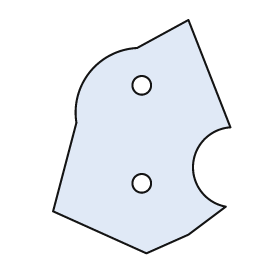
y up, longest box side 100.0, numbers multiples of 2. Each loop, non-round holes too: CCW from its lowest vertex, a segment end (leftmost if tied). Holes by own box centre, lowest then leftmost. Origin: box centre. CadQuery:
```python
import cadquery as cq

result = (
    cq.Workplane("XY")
    .moveTo(2.0, -50.0)
    .lineTo(20.0, -42.0)
    .lineTo(36.0, -30.0)
    .threePointArc((22.0, -12.0), (38.0, 4.0))
    .lineTo(20.0, 50.0)
    .lineTo(-2.0, 38.0)
    .threePointArc((-22.0, 28.0), (-28.0, 6.0))
    .lineTo(-38.0, -32.0)
    .close()
    .moveTo(0.0, -20.0)
    .circle(4.0)
    .moveTo(0.0, 22.0)
    .circle(4.0)
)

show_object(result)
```